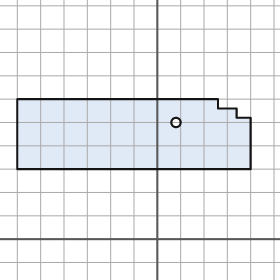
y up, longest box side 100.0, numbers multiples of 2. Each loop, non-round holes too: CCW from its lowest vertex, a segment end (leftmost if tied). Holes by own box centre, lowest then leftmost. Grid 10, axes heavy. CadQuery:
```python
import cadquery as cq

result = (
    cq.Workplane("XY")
    .moveTo(-60.0, 30.0)
    .lineTo(40.0, 30.0)
    .lineTo(40.0, 52.0)
    .lineTo(34.0, 52.0)
    .lineTo(34.0, 56.0)
    .lineTo(26.0, 56.0)
    .lineTo(26.0, 60.0)
    .lineTo(-60.0, 60.0)
    .close()
    .moveTo(8.0, 50.0)
    .circle(2.0)
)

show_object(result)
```